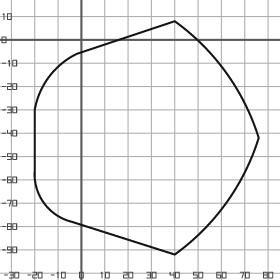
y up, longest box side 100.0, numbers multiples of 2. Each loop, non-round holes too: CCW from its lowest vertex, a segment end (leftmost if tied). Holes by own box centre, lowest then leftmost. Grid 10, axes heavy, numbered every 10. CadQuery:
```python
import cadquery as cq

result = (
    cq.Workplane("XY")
    .moveTo(40.0, -92.0)
    .threePointArc((62.0, -70.0), (76.0, -42.0))
    .threePointArc((62.0, -14.0), (40.0, 8.0))
    .lineTo(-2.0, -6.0)
    .threePointArc((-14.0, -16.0), (-20.0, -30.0))
    .lineTo(-20.0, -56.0)
    .threePointArc((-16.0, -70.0), (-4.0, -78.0))
    .close()
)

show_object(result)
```